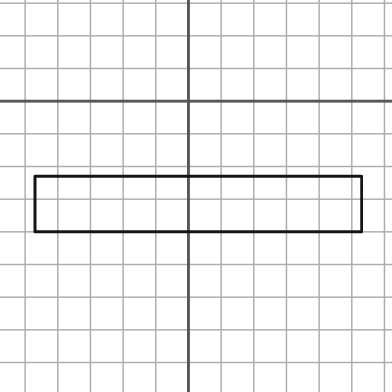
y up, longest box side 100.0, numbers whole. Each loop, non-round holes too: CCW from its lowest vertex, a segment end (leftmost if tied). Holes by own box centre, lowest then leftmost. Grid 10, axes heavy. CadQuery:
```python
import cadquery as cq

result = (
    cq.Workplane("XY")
    .moveTo(-47.0, -40.0)
    .lineTo(53.0, -40.0)
    .lineTo(53.0, -23.0)
    .lineTo(-47.0, -23.0)
    .close()
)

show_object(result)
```